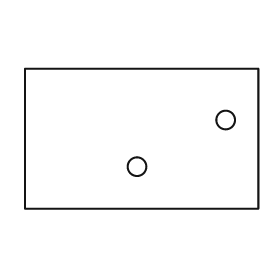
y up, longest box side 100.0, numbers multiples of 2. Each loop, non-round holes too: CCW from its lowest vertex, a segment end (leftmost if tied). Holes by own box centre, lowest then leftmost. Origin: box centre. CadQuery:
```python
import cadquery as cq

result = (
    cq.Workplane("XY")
    .moveTo(-50.0, -30.0)
    .lineTo(50.0, -30.0)
    .lineTo(50.0, 30.0)
    .lineTo(-50.0, 30.0)
    .close()
    .moveTo(-2.0, -12.0)
    .circle(4.0)
    .moveTo(36.0, 8.0)
    .circle(4.0)
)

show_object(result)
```